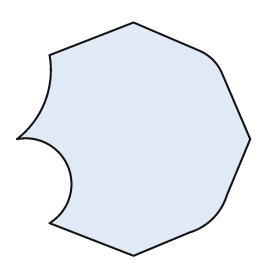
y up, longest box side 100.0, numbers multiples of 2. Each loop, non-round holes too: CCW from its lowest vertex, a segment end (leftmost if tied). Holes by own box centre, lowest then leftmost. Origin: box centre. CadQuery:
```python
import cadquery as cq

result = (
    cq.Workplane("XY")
    .moveTo(0.0, -50.0)
    .lineTo(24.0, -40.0)
    .threePointArc((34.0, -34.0), (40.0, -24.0))
    .lineTo(50.0, 0.0)
    .lineTo(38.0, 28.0)
    .threePointArc((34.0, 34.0), (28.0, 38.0))
    .lineTo(0.0, 50.0)
    .lineTo(-36.0, 36.0)
    .threePointArc((-38.0, 16.0), (-50.0, 0.0))
    .threePointArc((-28.0, -12.0), (-36.0, -36.0))
    .close()
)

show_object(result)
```